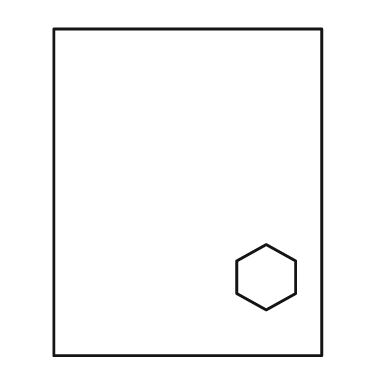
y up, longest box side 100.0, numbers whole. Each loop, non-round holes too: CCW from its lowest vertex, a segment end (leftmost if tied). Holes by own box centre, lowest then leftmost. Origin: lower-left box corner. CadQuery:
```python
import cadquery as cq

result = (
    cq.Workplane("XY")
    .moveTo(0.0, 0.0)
    .lineTo(82.0, 0.0)
    .lineTo(82.0, 100.0)
    .lineTo(0.0, 100.0)
    .close()
    .moveTo(65.0, 14.0)
    .lineTo(74.0, 19.0)
    .lineTo(74.0, 29.0)
    .lineTo(65.0, 34.0)
    .lineTo(56.0, 29.0)
    .lineTo(56.0, 19.0)
    .close()
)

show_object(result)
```